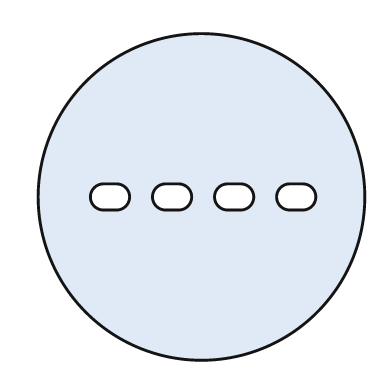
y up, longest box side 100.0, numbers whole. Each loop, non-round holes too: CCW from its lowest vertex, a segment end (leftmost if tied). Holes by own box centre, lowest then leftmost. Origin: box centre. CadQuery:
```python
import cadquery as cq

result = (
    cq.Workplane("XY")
    .moveTo(0.0, 0.0)
    .circle(50.0)
    .moveTo(-30.0, -4.0)
    .lineTo(-26.0, -4.0)
    .threePointArc((-22.0, 0.0), (-26.0, 4.0))
    .lineTo(-30.0, 4.0)
    .threePointArc((-34.0, 0.0), (-30.0, -4.0))
    .close()
    .moveTo(-11.0, -4.0)
    .lineTo(-7.0, -4.0)
    .threePointArc((-3.0, 0.0), (-7.0, 4.0))
    .lineTo(-11.0, 4.0)
    .threePointArc((-15.0, 0.0), (-11.0, -4.0))
    .close()
    .moveTo(8.0, -4.0)
    .lineTo(12.0, -4.0)
    .threePointArc((16.0, 0.0), (12.0, 4.0))
    .lineTo(8.0, 4.0)
    .threePointArc((4.0, 0.0), (8.0, -4.0))
    .close()
    .moveTo(27.0, -4.0)
    .lineTo(31.0, -4.0)
    .threePointArc((35.0, 0.0), (31.0, 4.0))
    .lineTo(27.0, 4.0)
    .threePointArc((23.0, 0.0), (27.0, -4.0))
    .close()
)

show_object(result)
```